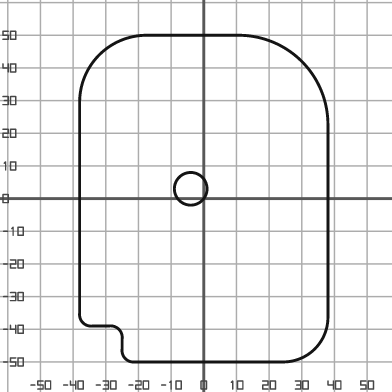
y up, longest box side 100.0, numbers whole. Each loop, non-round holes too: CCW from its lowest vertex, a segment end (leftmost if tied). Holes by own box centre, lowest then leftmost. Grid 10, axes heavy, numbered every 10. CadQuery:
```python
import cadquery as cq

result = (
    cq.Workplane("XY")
    .moveTo(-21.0, -50.0)
    .lineTo(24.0, -50.0)
    .threePointArc((34.0, -46.0), (38.0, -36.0))
    .lineTo(38.0, 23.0)
    .threePointArc((30.0, 42.0), (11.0, 50.0))
    .lineTo(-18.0, 50.0)
    .threePointArc((-32.0, 44.0), (-38.0, 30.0))
    .lineTo(-38.0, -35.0)
    .threePointArc((-37.0, -38.0), (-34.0, -39.0))
    .lineTo(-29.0, -39.0)
    .threePointArc((-26.0, -40.0), (-25.0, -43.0))
    .lineTo(-25.0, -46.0)
    .threePointArc((-24.0, -49.0), (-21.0, -50.0))
    .close()
    .moveTo(-4.0, 3.0)
    .circle(5.0)
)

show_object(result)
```